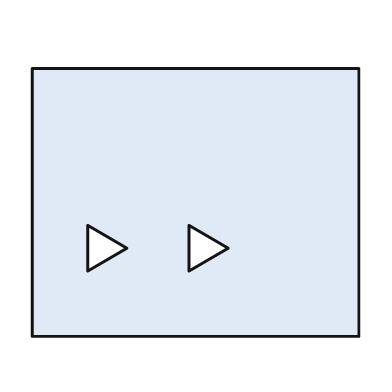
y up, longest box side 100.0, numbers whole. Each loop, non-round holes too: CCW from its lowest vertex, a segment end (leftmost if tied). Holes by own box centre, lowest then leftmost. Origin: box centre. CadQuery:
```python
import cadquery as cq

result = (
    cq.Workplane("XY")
    .moveTo(-50.0, -41.0)
    .lineTo(50.0, -41.0)
    .lineTo(50.0, 41.0)
    .lineTo(-50.0, 41.0)
    .close()
    .moveTo(-33.0, -21.0)
    .lineTo(-21.0, -14.0)
    .lineTo(-33.0, -7.0)
    .close()
    .moveTo(-2.0, -21.0)
    .lineTo(10.0, -14.0)
    .lineTo(-2.0, -7.0)
    .close()
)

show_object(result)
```